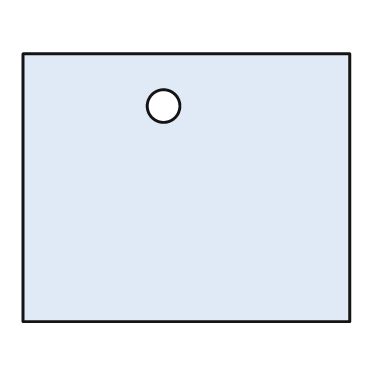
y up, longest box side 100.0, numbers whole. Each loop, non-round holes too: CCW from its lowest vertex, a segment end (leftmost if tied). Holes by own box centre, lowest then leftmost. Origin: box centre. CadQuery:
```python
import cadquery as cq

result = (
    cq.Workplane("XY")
    .moveTo(-50.0, -41.0)
    .lineTo(50.0, -41.0)
    .lineTo(50.0, 41.0)
    .lineTo(-50.0, 41.0)
    .close()
    .moveTo(-7.0, 25.0)
    .circle(5.0)
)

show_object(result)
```